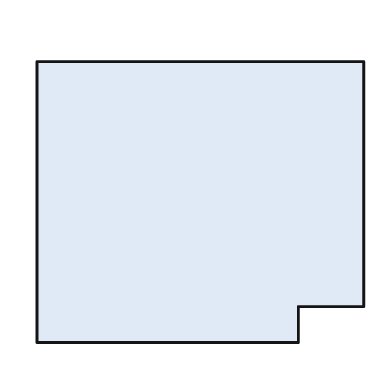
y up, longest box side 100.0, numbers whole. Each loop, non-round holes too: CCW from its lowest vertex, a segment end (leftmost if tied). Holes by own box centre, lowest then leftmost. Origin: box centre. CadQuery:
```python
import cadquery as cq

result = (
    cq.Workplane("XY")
    .moveTo(-50.0, -43.0)
    .lineTo(30.0, -43.0)
    .lineTo(30.0, -32.0)
    .lineTo(50.0, -32.0)
    .lineTo(50.0, 43.0)
    .lineTo(-50.0, 43.0)
    .close()
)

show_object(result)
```